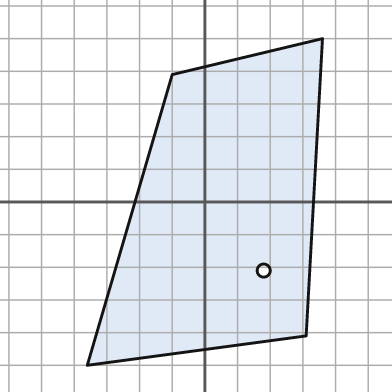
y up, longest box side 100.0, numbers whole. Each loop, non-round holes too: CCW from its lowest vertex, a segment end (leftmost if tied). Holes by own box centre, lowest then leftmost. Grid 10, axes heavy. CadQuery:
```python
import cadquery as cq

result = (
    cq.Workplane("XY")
    .moveTo(-36.0, -50.0)
    .lineTo(31.0, -41.0)
    .lineTo(36.0, 50.0)
    .lineTo(-10.0, 39.0)
    .close()
    .moveTo(18.0, -21.0)
    .circle(2.0)
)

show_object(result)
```